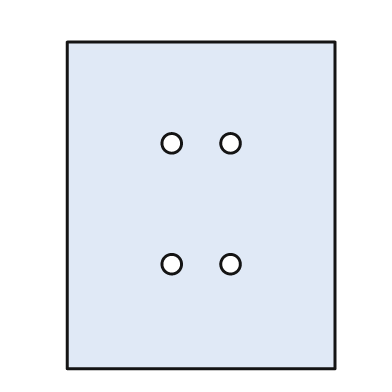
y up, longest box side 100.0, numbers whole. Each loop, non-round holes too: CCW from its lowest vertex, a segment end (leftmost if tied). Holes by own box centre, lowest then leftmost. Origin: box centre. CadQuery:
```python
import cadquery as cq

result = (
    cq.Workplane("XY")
    .moveTo(-41.0, -50.0)
    .lineTo(41.0, -50.0)
    .lineTo(41.0, 50.0)
    .lineTo(-41.0, 50.0)
    .close()
    .moveTo(-9.0, -18.0)
    .circle(3.0)
    .moveTo(9.0, -18.0)
    .circle(3.0)
    .moveTo(-9.0, 19.0)
    .circle(3.0)
    .moveTo(9.0, 19.0)
    .circle(3.0)
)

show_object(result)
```